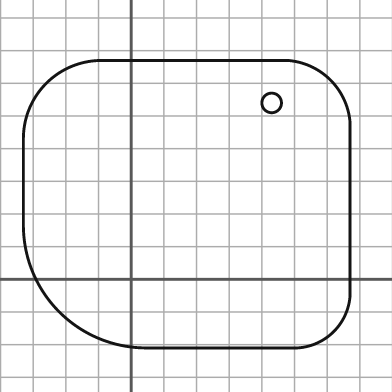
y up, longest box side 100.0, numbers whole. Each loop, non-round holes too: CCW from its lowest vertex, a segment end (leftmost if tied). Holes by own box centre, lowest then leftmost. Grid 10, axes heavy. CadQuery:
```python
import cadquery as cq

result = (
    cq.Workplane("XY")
    .moveTo(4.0, -21.0)
    .lineTo(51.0, -21.0)
    .threePointArc((62.0, -16.0), (67.0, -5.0))
    .lineTo(67.0, 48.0)
    .threePointArc((61.0, 61.0), (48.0, 67.0))
    .lineTo(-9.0, 67.0)
    .threePointArc((-26.0, 60.0), (-33.0, 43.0))
    .lineTo(-33.0, 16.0)
    .threePointArc((-22.0, -10.0), (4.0, -21.0))
    .close()
    .moveTo(43.0, 54.0)
    .circle(3.0)
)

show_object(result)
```